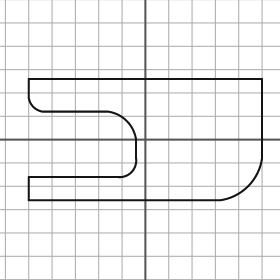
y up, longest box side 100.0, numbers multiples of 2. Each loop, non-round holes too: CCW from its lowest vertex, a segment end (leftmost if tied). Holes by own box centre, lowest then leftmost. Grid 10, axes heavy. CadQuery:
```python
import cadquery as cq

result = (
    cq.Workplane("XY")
    .moveTo(-50.0, -26.0)
    .lineTo(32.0, -26.0)
    .threePointArc((44.0, -20.0), (50.0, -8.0))
    .lineTo(50.0, 26.0)
    .lineTo(-50.0, 26.0)
    .lineTo(-50.0, 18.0)
    .threePointArc((-48.0, 14.0), (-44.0, 12.0))
    .lineTo(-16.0, 12.0)
    .threePointArc((-8.0, 8.0), (-4.0, 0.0))
    .lineTo(-4.0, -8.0)
    .threePointArc((-6.0, -14.0), (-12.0, -16.0))
    .lineTo(-50.0, -16.0)
    .close()
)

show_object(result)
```